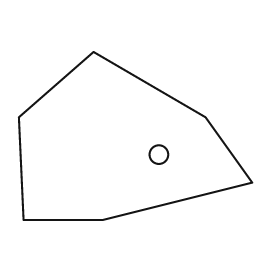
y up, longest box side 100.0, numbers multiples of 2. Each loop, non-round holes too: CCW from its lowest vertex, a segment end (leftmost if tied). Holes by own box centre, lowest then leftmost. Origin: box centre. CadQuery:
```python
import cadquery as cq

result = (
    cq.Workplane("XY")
    .moveTo(-48.0, -36.0)
    .lineTo(-14.0, -36.0)
    .lineTo(50.0, -20.0)
    .lineTo(30.0, 8.0)
    .lineTo(-18.0, 36.0)
    .lineTo(-50.0, 8.0)
    .close()
    .moveTo(10.0, -8.0)
    .circle(4.0)
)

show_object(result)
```